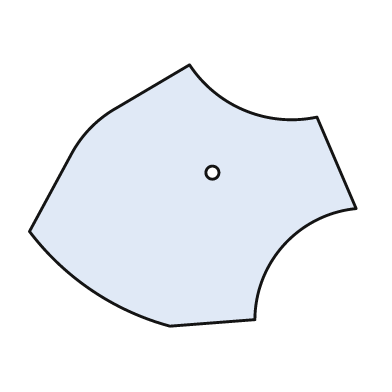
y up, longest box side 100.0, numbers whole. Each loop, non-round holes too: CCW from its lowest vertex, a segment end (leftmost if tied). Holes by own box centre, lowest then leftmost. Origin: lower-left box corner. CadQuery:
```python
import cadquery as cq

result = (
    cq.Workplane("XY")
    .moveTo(43.0, 0.0)
    .lineTo(69.0, 2.0)
    .threePointArc((78.0, 25.0), (100.0, 36.0))
    .lineTo(88.0, 64.0)
    .threePointArc((66.0, 66.0), (49.0, 80.0))
    .lineTo(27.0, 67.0)
    .threePointArc((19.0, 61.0), (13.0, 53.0))
    .lineTo(0.0, 29.0)
    .threePointArc((19.0, 11.0), (43.0, 0.0))
    .close()
    .moveTo(56.0, 47.0)
    .circle(2.0)
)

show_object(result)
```